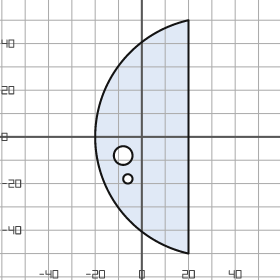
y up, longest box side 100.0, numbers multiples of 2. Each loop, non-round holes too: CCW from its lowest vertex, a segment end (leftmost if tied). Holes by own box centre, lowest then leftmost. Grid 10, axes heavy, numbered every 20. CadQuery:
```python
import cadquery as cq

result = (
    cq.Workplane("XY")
    .moveTo(20.0, -50.0)
    .lineTo(20.0, 50.0)
    .threePointArc((-20.0, 0.0), (20.0, -50.0))
    .close()
    .moveTo(-6.0, -18.0)
    .circle(2.0)
    .moveTo(-8.0, -8.0)
    .circle(4.0)
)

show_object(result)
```